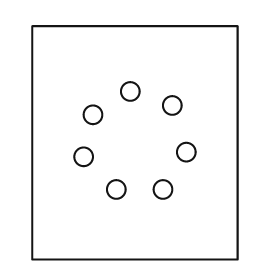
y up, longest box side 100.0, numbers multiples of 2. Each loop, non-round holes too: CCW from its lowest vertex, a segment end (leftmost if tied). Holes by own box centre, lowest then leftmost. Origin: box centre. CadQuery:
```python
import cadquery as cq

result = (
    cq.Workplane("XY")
    .moveTo(-44.0, -50.0)
    .lineTo(44.0, -50.0)
    .lineTo(44.0, 50.0)
    .lineTo(-44.0, 50.0)
    .close()
    .moveTo(-8.0, -20.0)
    .circle(4.0)
    .moveTo(12.0, -20.0)
    .circle(4.0)
    .moveTo(-22.0, -6.0)
    .circle(4.0)
    .moveTo(22.0, -4.0)
    .circle(4.0)
    .moveTo(-18.0, 12.0)
    .circle(4.0)
    .moveTo(16.0, 16.0)
    .circle(4.0)
    .moveTo(-2.0, 22.0)
    .circle(4.0)
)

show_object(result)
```